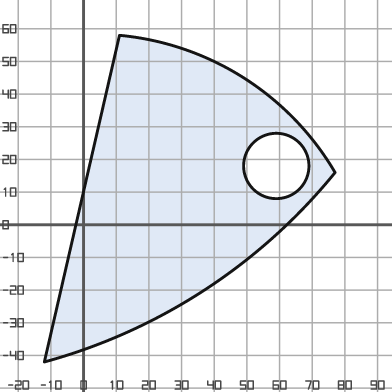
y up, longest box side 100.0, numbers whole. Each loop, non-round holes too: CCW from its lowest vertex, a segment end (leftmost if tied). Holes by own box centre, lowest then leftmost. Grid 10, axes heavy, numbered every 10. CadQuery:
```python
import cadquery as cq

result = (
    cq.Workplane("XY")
    .moveTo(-12.0, -42.0)
    .threePointArc((37.0, -20.0), (77.0, 16.0))
    .threePointArc((49.0, 45.0), (11.0, 58.0))
    .close()
    .moveTo(59.0, 18.0)
    .circle(10.0)
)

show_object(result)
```